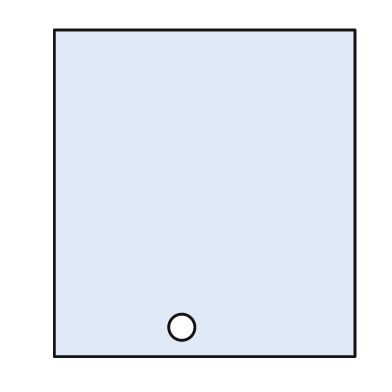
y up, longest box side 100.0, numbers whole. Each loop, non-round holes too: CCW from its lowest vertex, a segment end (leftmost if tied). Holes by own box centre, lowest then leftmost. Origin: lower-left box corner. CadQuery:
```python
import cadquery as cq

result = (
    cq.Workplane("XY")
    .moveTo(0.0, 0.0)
    .lineTo(92.0, 0.0)
    .lineTo(92.0, 100.0)
    .lineTo(0.0, 100.0)
    .close()
    .moveTo(39.0, 9.0)
    .circle(4.0)
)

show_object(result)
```